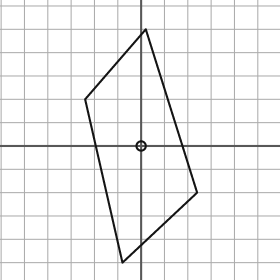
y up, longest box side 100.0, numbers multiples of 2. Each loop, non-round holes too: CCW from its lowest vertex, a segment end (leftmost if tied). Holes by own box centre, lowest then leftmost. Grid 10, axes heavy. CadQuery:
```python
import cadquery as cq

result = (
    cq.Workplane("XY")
    .moveTo(-8.0, -50.0)
    .lineTo(24.0, -20.0)
    .lineTo(2.0, 50.0)
    .lineTo(-24.0, 20.0)
    .close()
    .moveTo(0.0, 0.0)
    .circle(2.0)
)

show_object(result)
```